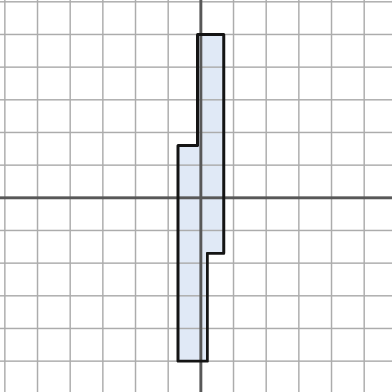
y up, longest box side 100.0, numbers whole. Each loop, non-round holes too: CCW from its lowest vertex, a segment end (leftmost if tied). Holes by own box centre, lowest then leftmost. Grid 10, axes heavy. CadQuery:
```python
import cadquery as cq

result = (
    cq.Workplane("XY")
    .moveTo(-7.0, -50.0)
    .lineTo(2.0, -50.0)
    .lineTo(2.0, -17.0)
    .lineTo(7.0, -17.0)
    .lineTo(7.0, 50.0)
    .lineTo(-1.0, 50.0)
    .lineTo(-1.0, 16.0)
    .lineTo(-7.0, 16.0)
    .close()
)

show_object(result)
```